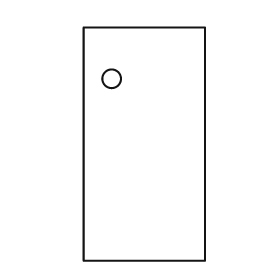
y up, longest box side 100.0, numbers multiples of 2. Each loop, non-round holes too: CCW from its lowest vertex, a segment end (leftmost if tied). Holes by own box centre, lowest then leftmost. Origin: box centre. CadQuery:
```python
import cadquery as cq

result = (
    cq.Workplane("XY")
    .moveTo(-26.0, -50.0)
    .lineTo(26.0, -50.0)
    .lineTo(26.0, 50.0)
    .lineTo(-26.0, 50.0)
    .close()
    .moveTo(-14.0, 28.0)
    .circle(4.0)
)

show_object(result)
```